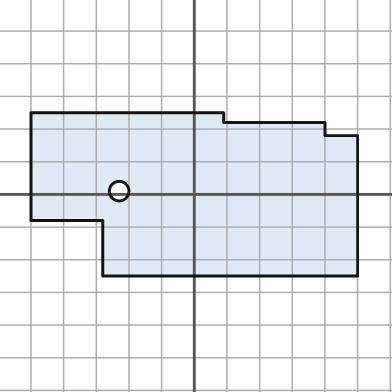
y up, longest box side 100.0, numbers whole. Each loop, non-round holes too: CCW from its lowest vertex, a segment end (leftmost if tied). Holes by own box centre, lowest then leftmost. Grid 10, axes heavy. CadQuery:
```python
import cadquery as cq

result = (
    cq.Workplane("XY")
    .moveTo(-28.0, -25.0)
    .lineTo(50.0, -25.0)
    .lineTo(50.0, 18.0)
    .lineTo(40.0, 18.0)
    .lineTo(40.0, 22.0)
    .lineTo(9.0, 22.0)
    .lineTo(9.0, 25.0)
    .lineTo(-50.0, 25.0)
    .lineTo(-50.0, -8.0)
    .lineTo(-28.0, -8.0)
    .close()
    .moveTo(-23.0, 1.0)
    .circle(3.0)
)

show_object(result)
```